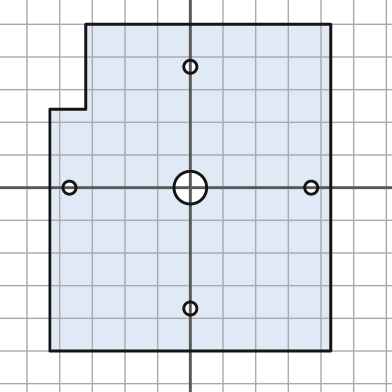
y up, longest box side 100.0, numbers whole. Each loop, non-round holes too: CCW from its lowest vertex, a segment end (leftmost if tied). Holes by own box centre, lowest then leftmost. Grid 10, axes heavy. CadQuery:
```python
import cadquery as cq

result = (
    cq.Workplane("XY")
    .moveTo(-43.0, -50.0)
    .lineTo(43.0, -50.0)
    .lineTo(43.0, 50.0)
    .lineTo(-32.0, 50.0)
    .lineTo(-32.0, 24.0)
    .lineTo(-43.0, 24.0)
    .close()
    .moveTo(0.0, -37.0)
    .circle(2.0)
    .moveTo(-37.0, 0.0)
    .circle(2.0)
    .moveTo(0.0, 0.0)
    .circle(5.0)
    .moveTo(37.0, 0.0)
    .circle(2.0)
    .moveTo(0.0, 37.0)
    .circle(2.0)
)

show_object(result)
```